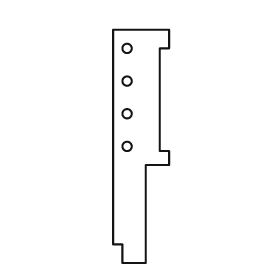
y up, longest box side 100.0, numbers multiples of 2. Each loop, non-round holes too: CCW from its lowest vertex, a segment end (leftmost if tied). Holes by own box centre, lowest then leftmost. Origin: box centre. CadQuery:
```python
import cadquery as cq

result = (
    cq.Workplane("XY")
    .moveTo(-8.0, -50.0)
    .lineTo(2.0, -50.0)
    .lineTo(2.0, -8.0)
    .lineTo(12.0, -8.0)
    .lineTo(12.0, -2.0)
    .lineTo(8.0, -2.0)
    .lineTo(8.0, 42.0)
    .lineTo(12.0, 42.0)
    .lineTo(12.0, 50.0)
    .lineTo(-12.0, 50.0)
    .lineTo(-12.0, -42.0)
    .lineTo(-8.0, -42.0)
    .close()
    .moveTo(-6.0, 0.0)
    .circle(2.0)
    .moveTo(-6.0, 14.0)
    .circle(2.0)
    .moveTo(-6.0, 28.0)
    .circle(2.0)
    .moveTo(-6.0, 42.0)
    .circle(2.0)
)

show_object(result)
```